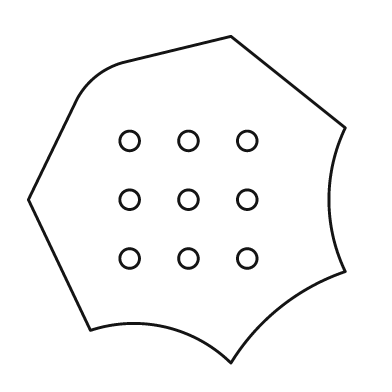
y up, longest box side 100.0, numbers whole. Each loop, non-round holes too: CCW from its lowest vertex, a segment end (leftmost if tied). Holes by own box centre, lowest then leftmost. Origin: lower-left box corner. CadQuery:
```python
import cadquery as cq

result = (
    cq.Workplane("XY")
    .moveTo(62.0, 0.0)
    .threePointArc((77.0, 17.0), (97.0, 28.0))
    .threePointArc((92.0, 50.0), (97.0, 72.0))
    .lineTo(62.0, 100.0)
    .lineTo(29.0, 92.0)
    .threePointArc((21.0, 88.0), (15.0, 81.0))
    .lineTo(0.0, 50.0)
    .lineTo(19.0, 10.0)
    .threePointArc((42.0, 11.0), (62.0, 0.0))
    .close()
    .moveTo(31.0, 32.0)
    .circle(3.0)
    .moveTo(49.0, 32.0)
    .circle(3.0)
    .moveTo(67.0, 32.0)
    .circle(3.0)
    .moveTo(31.0, 50.0)
    .circle(3.0)
    .moveTo(49.0, 50.0)
    .circle(3.0)
    .moveTo(67.0, 50.0)
    .circle(3.0)
    .moveTo(31.0, 68.0)
    .circle(3.0)
    .moveTo(49.0, 68.0)
    .circle(3.0)
    .moveTo(67.0, 68.0)
    .circle(3.0)
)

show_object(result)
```